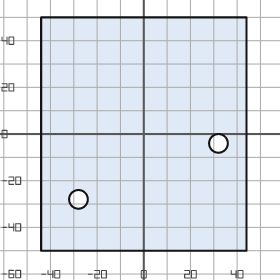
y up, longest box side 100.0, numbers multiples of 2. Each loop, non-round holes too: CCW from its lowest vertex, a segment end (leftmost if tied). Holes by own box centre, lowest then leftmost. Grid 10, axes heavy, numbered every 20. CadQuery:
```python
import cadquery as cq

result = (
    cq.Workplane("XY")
    .moveTo(-44.0, -50.0)
    .lineTo(44.0, -50.0)
    .lineTo(44.0, 50.0)
    .lineTo(-44.0, 50.0)
    .close()
    .moveTo(-28.0, -28.0)
    .circle(4.0)
    .moveTo(32.0, -4.0)
    .circle(4.0)
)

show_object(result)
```